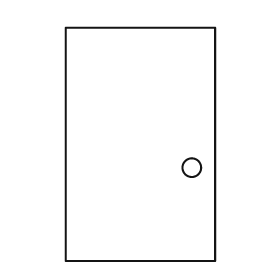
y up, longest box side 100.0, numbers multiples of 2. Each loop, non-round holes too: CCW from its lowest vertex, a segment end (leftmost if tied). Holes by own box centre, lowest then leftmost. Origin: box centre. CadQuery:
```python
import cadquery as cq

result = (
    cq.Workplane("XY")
    .moveTo(-32.0, -50.0)
    .lineTo(32.0, -50.0)
    .lineTo(32.0, 50.0)
    .lineTo(-32.0, 50.0)
    .close()
    .moveTo(22.0, -10.0)
    .circle(4.0)
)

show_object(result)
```